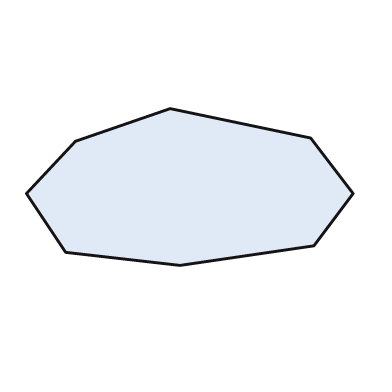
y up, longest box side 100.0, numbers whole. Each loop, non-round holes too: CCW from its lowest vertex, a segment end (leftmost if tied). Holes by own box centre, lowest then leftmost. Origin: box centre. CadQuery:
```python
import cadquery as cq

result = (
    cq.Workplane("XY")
    .moveTo(-3.0, -24.0)
    .lineTo(38.0, -18.0)
    .lineTo(50.0, -2.0)
    .lineTo(37.0, 15.0)
    .lineTo(-6.0, 24.0)
    .lineTo(-35.0, 14.0)
    .lineTo(-50.0, -2.0)
    .lineTo(-38.0, -20.0)
    .close()
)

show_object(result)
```